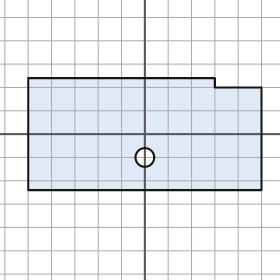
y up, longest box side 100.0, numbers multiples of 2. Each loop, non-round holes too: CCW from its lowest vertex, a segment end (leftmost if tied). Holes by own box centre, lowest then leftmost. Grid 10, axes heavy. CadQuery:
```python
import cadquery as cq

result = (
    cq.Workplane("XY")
    .moveTo(-50.0, -24.0)
    .lineTo(50.0, -24.0)
    .lineTo(50.0, 20.0)
    .lineTo(30.0, 20.0)
    .lineTo(30.0, 24.0)
    .lineTo(-50.0, 24.0)
    .close()
    .moveTo(0.0, -10.0)
    .circle(4.0)
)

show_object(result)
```